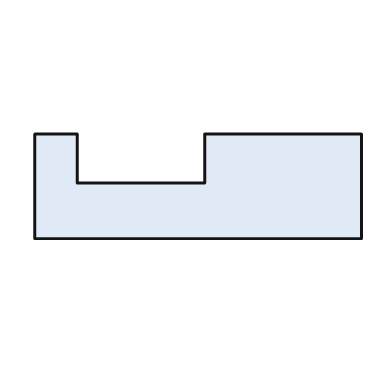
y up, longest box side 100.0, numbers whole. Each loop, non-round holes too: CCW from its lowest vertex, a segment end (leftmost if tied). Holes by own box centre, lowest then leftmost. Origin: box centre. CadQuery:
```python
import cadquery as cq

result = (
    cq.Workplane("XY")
    .moveTo(-50.0, -16.0)
    .lineTo(50.0, -16.0)
    .lineTo(50.0, 16.0)
    .lineTo(2.0, 16.0)
    .lineTo(2.0, 1.0)
    .lineTo(-37.0, 1.0)
    .lineTo(-37.0, 16.0)
    .lineTo(-50.0, 16.0)
    .close()
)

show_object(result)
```